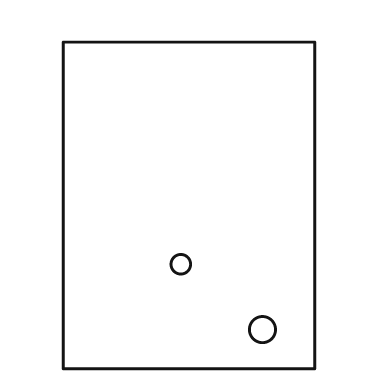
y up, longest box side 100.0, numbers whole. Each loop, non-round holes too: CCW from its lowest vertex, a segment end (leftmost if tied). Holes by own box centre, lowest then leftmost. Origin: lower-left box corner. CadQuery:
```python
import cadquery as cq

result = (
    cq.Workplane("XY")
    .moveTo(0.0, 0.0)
    .lineTo(77.0, 0.0)
    .lineTo(77.0, 100.0)
    .lineTo(0.0, 100.0)
    .close()
    .moveTo(61.0, 12.0)
    .circle(4.0)
    .moveTo(36.0, 32.0)
    .circle(3.0)
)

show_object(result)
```